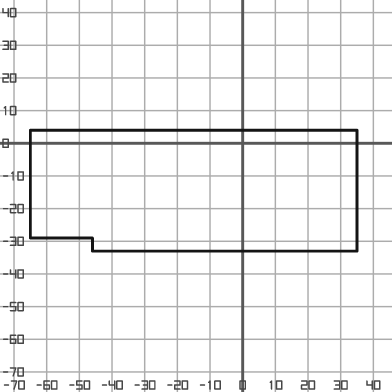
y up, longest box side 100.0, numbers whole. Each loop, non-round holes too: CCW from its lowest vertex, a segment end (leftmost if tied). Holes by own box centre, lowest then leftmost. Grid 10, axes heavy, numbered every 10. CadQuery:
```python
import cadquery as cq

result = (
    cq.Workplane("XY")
    .moveTo(-46.0, -33.0)
    .lineTo(35.0, -33.0)
    .lineTo(35.0, 4.0)
    .lineTo(-65.0, 4.0)
    .lineTo(-65.0, -29.0)
    .lineTo(-46.0, -29.0)
    .close()
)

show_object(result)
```